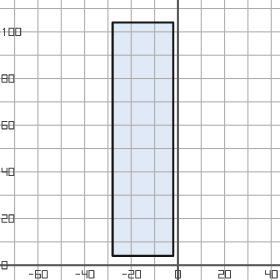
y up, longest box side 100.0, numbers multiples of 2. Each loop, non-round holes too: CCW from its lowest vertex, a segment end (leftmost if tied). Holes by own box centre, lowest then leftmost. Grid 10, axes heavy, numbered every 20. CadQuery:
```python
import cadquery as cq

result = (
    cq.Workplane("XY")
    .moveTo(-28.0, 4.0)
    .lineTo(-2.0, 4.0)
    .lineTo(-2.0, 104.0)
    .lineTo(-28.0, 104.0)
    .close()
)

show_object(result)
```